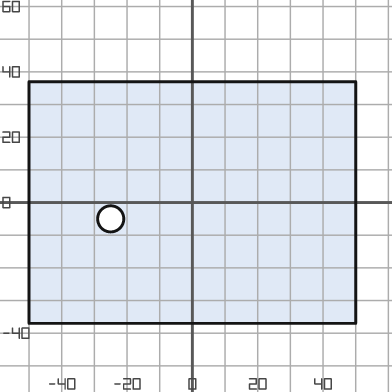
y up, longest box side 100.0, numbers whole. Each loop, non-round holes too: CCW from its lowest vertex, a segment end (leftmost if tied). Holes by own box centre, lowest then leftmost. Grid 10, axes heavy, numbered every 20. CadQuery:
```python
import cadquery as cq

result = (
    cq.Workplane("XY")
    .moveTo(-50.0, -37.0)
    .lineTo(50.0, -37.0)
    .lineTo(50.0, 37.0)
    .lineTo(-50.0, 37.0)
    .close()
    .moveTo(-25.0, -5.0)
    .circle(4.0)
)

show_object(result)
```